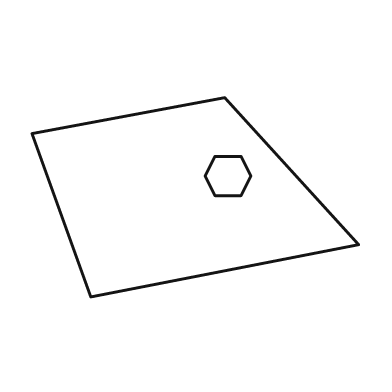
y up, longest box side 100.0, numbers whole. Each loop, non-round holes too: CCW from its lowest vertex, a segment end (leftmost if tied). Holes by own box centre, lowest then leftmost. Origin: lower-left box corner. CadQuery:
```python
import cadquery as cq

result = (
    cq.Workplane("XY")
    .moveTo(18.0, 0.0)
    .lineTo(100.0, 16.0)
    .lineTo(59.0, 61.0)
    .lineTo(0.0, 50.0)
    .close()
    .moveTo(56.0, 31.0)
    .lineTo(64.0, 31.0)
    .lineTo(67.0, 37.0)
    .lineTo(64.0, 43.0)
    .lineTo(56.0, 43.0)
    .lineTo(53.0, 37.0)
    .close()
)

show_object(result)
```